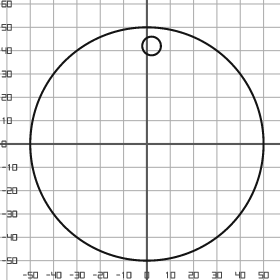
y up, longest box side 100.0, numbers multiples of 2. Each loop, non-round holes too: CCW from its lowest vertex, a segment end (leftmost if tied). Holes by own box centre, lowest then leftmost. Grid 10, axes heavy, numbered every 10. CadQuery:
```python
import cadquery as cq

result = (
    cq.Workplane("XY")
    .moveTo(0.0, 0.0)
    .circle(50.0)
    .moveTo(2.0, 42.0)
    .circle(4.0)
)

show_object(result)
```